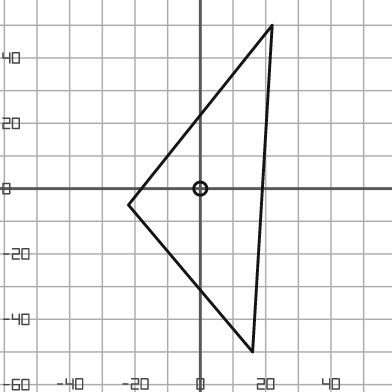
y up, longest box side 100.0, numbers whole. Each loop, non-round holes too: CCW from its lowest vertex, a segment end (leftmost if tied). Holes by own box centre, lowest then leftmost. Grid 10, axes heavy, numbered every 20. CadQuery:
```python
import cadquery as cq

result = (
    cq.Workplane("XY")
    .moveTo(16.0, -50.0)
    .lineTo(22.0, 50.0)
    .lineTo(-22.0, -5.0)
    .close()
    .moveTo(0.0, 0.0)
    .circle(2.0)
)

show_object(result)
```